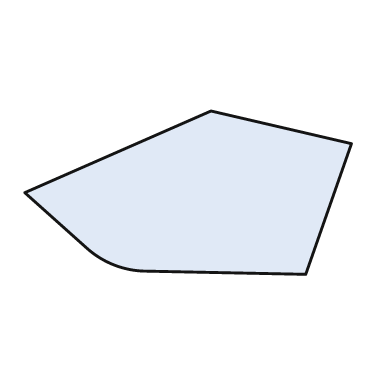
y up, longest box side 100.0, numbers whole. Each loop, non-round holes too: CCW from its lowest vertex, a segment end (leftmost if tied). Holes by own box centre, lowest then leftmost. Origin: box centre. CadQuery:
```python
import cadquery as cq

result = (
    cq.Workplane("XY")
    .moveTo(36.0, -25.0)
    .lineTo(50.0, 15.0)
    .lineTo(7.0, 25.0)
    .lineTo(-50.0, 0.0)
    .lineTo(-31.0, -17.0)
    .threePointArc((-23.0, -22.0), (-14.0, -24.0))
    .close()
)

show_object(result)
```